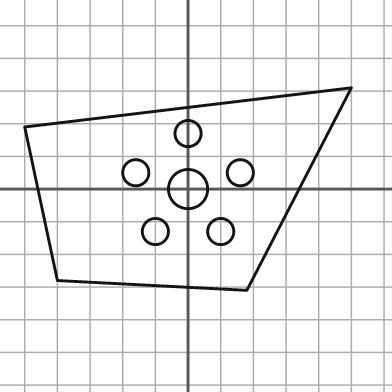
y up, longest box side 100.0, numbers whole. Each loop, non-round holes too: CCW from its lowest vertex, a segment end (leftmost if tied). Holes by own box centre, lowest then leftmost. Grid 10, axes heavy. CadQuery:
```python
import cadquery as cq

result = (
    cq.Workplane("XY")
    .moveTo(18.0, -31.0)
    .lineTo(50.0, 31.0)
    .lineTo(-50.0, 19.0)
    .lineTo(-40.0, -28.0)
    .close()
    .moveTo(-10.0, -13.0)
    .circle(4.0)
    .moveTo(10.0, -13.0)
    .circle(4.0)
    .moveTo(0.0, 0.0)
    .circle(6.0)
    .moveTo(-16.0, 5.0)
    .circle(4.0)
    .moveTo(16.0, 5.0)
    .circle(4.0)
    .moveTo(0.0, 17.0)
    .circle(4.0)
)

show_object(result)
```